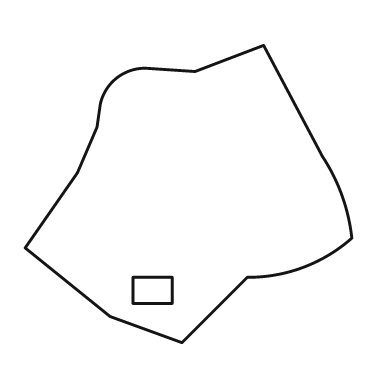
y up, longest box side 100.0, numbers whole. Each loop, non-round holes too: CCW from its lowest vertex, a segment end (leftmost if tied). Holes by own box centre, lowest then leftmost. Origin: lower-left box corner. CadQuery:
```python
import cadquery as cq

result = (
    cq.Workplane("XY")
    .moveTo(48.0, 0.0)
    .lineTo(68.0, 20.0)
    .threePointArc((85.0, 23.0), (100.0, 32.0))
    .threePointArc((97.0, 45.0), (91.0, 57.0))
    .lineTo(73.0, 91.0)
    .lineTo(52.0, 83.0)
    .lineTo(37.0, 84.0)
    .threePointArc((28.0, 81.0), (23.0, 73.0))
    .lineTo(22.0, 66.0)
    .lineTo(16.0, 52.0)
    .lineTo(0.0, 29.0)
    .lineTo(26.0, 8.0)
    .close()
    .moveTo(33.0, 12.0)
    .lineTo(45.0, 12.0)
    .lineTo(45.0, 20.0)
    .lineTo(33.0, 20.0)
    .close()
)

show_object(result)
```